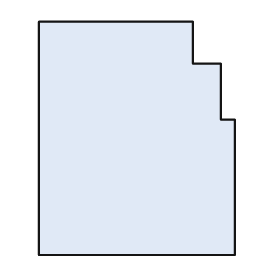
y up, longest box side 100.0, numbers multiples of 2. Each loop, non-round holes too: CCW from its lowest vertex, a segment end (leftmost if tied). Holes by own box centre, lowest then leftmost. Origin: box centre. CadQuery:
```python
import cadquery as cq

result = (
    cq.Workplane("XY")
    .moveTo(-42.0, -50.0)
    .lineTo(42.0, -50.0)
    .lineTo(42.0, 8.0)
    .lineTo(36.0, 8.0)
    .lineTo(36.0, 32.0)
    .lineTo(24.0, 32.0)
    .lineTo(24.0, 50.0)
    .lineTo(-42.0, 50.0)
    .close()
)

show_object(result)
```